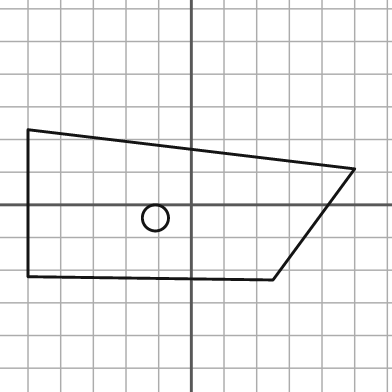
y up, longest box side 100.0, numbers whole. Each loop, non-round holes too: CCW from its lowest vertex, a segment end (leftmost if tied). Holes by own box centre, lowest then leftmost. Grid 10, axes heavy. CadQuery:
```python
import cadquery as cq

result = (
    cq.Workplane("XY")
    .moveTo(25.0, -23.0)
    .lineTo(50.0, 11.0)
    .lineTo(-50.0, 23.0)
    .lineTo(-50.0, -22.0)
    .close()
    .moveTo(-11.0, -4.0)
    .circle(4.0)
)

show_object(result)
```